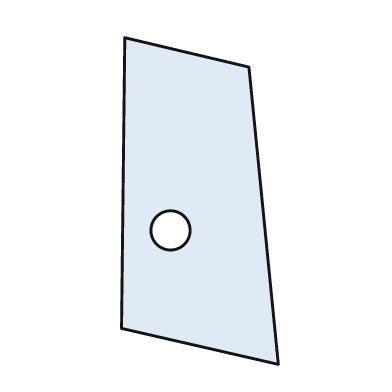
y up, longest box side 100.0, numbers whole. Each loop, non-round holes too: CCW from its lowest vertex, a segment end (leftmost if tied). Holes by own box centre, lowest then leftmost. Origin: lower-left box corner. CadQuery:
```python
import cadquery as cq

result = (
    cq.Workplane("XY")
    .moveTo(48.0, 0.0)
    .lineTo(39.0, 91.0)
    .lineTo(1.0, 100.0)
    .lineTo(0.0, 11.0)
    .close()
    .moveTo(15.0, 41.0)
    .circle(6.0)
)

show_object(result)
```